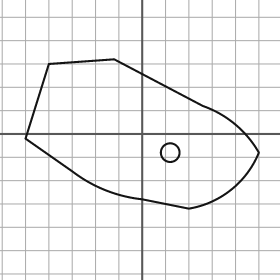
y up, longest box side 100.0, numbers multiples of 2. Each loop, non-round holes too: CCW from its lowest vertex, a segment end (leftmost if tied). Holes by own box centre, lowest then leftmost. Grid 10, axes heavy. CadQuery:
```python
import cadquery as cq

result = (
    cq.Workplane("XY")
    .moveTo(20.0, -32.0)
    .threePointArc((38.0, -24.0), (50.0, -8.0))
    .threePointArc((40.0, 4.0), (26.0, 12.0))
    .lineTo(-12.0, 32.0)
    .lineTo(-40.0, 30.0)
    .lineTo(-50.0, -2.0)
    .lineTo(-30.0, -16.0)
    .threePointArc((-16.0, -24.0), (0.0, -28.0))
    .close()
    .moveTo(12.0, -8.0)
    .circle(4.0)
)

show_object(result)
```